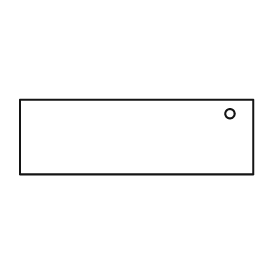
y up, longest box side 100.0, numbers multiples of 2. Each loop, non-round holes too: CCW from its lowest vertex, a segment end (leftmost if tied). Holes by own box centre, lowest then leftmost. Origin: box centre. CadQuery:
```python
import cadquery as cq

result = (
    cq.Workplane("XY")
    .moveTo(-50.0, -16.0)
    .lineTo(50.0, -16.0)
    .lineTo(50.0, 16.0)
    .lineTo(-50.0, 16.0)
    .close()
    .moveTo(40.0, 10.0)
    .circle(2.0)
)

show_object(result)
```